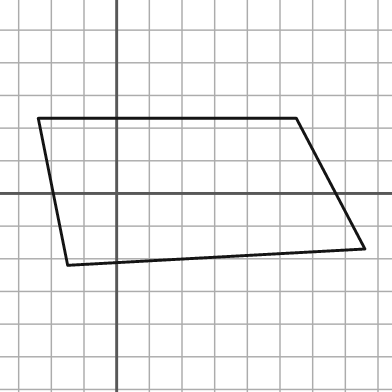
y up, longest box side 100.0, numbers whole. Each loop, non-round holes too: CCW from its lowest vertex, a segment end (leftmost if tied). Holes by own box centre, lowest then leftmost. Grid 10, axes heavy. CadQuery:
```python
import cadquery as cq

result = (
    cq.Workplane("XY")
    .moveTo(-15.0, -22.0)
    .lineTo(76.0, -17.0)
    .lineTo(55.0, 23.0)
    .lineTo(-24.0, 23.0)
    .close()
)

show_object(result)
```